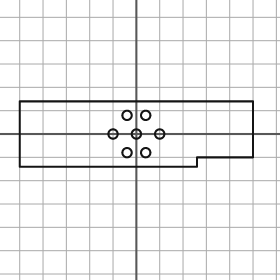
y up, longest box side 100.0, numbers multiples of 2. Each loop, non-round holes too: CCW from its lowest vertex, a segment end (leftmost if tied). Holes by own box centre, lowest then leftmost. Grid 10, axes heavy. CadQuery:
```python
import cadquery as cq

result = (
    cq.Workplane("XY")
    .moveTo(-50.0, -14.0)
    .lineTo(26.0, -14.0)
    .lineTo(26.0, -10.0)
    .lineTo(50.0, -10.0)
    .lineTo(50.0, 14.0)
    .lineTo(-50.0, 14.0)
    .close()
    .moveTo(-4.0, -8.0)
    .circle(2.0)
    .moveTo(4.0, -8.0)
    .circle(2.0)
    .moveTo(-10.0, 0.0)
    .circle(2.0)
    .moveTo(0.0, 0.0)
    .circle(2.0)
    .moveTo(10.0, 0.0)
    .circle(2.0)
    .moveTo(-4.0, 8.0)
    .circle(2.0)
    .moveTo(4.0, 8.0)
    .circle(2.0)
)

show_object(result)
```